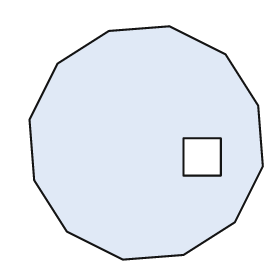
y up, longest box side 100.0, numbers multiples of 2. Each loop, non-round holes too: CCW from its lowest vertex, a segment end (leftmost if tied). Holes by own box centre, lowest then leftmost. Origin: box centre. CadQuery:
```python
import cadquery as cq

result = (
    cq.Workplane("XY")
    .moveTo(-10.0, -50.0)
    .lineTo(16.0, -48.0)
    .lineTo(38.0, -34.0)
    .lineTo(50.0, -10.0)
    .lineTo(48.0, 16.0)
    .lineTo(34.0, 38.0)
    .lineTo(10.0, 50.0)
    .lineTo(-16.0, 48.0)
    .lineTo(-38.0, 34.0)
    .lineTo(-50.0, 10.0)
    .lineTo(-48.0, -16.0)
    .lineTo(-34.0, -38.0)
    .close()
    .moveTo(16.0, -14.0)
    .lineTo(32.0, -14.0)
    .lineTo(32.0, 2.0)
    .lineTo(16.0, 2.0)
    .close()
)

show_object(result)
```